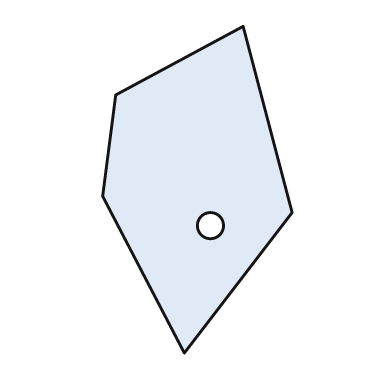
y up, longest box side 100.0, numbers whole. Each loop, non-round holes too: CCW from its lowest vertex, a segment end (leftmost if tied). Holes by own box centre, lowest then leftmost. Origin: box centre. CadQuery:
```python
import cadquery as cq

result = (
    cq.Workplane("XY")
    .moveTo(-4.0, -50.0)
    .lineTo(29.0, -7.0)
    .lineTo(14.0, 50.0)
    .lineTo(-25.0, 29.0)
    .lineTo(-29.0, -2.0)
    .close()
    .moveTo(4.0, -11.0)
    .circle(4.0)
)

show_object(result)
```